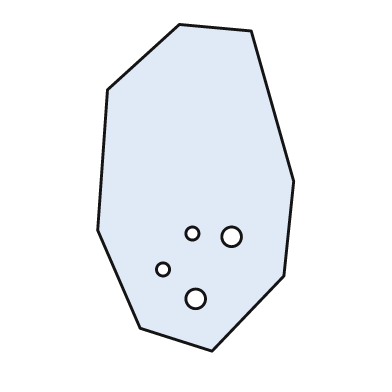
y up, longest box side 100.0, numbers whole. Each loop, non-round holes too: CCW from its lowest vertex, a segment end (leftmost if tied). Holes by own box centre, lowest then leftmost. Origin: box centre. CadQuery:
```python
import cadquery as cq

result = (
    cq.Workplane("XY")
    .moveTo(5.0, -50.0)
    .lineTo(27.0, -27.0)
    .lineTo(30.0, 2.0)
    .lineTo(17.0, 48.0)
    .lineTo(-5.0, 50.0)
    .lineTo(-27.0, 30.0)
    .lineTo(-30.0, -13.0)
    .lineTo(-17.0, -43.0)
    .close()
    .moveTo(0.0, -34.0)
    .circle(3.0)
    .moveTo(-10.0, -25.0)
    .circle(2.0)
    .moveTo(11.0, -15.0)
    .circle(3.0)
    .moveTo(-1.0, -14.0)
    .circle(2.0)
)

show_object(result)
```